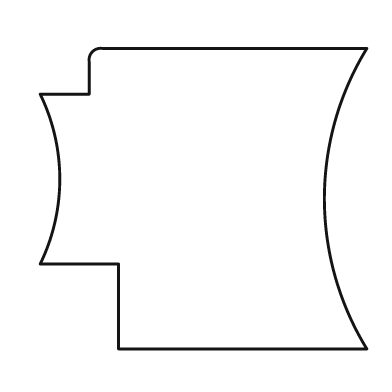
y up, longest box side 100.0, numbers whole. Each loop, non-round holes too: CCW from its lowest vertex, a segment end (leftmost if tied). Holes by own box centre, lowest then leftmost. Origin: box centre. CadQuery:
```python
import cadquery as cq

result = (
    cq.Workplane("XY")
    .moveTo(-26.0, -46.0)
    .lineTo(50.0, -46.0)
    .threePointArc((37.0, 0.0), (50.0, 46.0))
    .lineTo(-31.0, 46.0)
    .threePointArc((-34.0, 45.0), (-35.0, 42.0))
    .lineTo(-35.0, 32.0)
    .lineTo(-50.0, 32.0)
    .threePointArc((-44.0, 6.0), (-50.0, -20.0))
    .lineTo(-26.0, -20.0)
    .close()
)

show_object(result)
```